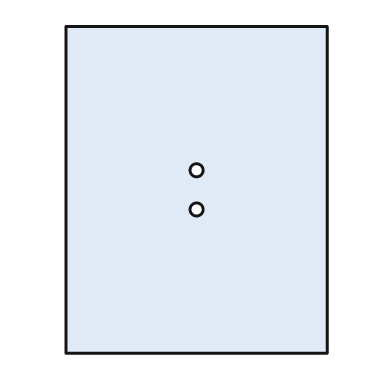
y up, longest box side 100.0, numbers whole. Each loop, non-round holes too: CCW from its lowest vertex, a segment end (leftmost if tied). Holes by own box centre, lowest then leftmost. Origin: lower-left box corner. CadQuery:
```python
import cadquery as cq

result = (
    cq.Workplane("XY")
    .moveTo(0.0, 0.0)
    .lineTo(80.0, 0.0)
    .lineTo(80.0, 100.0)
    .lineTo(0.0, 100.0)
    .close()
    .moveTo(40.0, 44.0)
    .circle(2.0)
    .moveTo(40.0, 56.0)
    .circle(2.0)
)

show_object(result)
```